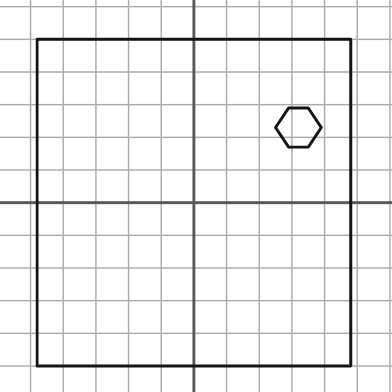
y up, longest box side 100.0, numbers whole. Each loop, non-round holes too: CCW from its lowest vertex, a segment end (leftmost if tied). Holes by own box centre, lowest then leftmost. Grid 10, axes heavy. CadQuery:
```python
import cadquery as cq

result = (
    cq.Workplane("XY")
    .moveTo(-48.0, -50.0)
    .lineTo(48.0, -50.0)
    .lineTo(48.0, 50.0)
    .lineTo(-48.0, 50.0)
    .close()
    .moveTo(29.0, 17.0)
    .lineTo(35.0, 17.0)
    .lineTo(39.0, 23.0)
    .lineTo(35.0, 29.0)
    .lineTo(29.0, 29.0)
    .lineTo(25.0, 23.0)
    .close()
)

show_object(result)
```